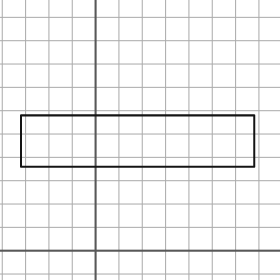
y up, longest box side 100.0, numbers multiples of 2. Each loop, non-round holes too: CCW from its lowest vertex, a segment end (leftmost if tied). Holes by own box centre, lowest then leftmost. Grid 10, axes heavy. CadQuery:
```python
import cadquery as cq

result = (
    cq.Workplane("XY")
    .moveTo(-32.0, 36.0)
    .lineTo(68.0, 36.0)
    .lineTo(68.0, 58.0)
    .lineTo(-32.0, 58.0)
    .close()
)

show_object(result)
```